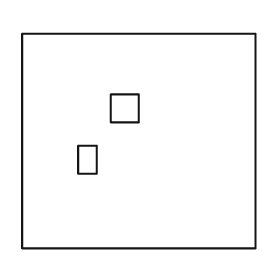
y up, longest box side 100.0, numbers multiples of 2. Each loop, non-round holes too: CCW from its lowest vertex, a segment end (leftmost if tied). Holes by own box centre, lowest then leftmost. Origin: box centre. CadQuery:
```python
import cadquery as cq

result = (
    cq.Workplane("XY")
    .moveTo(-50.0, -46.0)
    .lineTo(50.0, -46.0)
    .lineTo(50.0, 46.0)
    .lineTo(-50.0, 46.0)
    .close()
    .moveTo(-26.0, -14.0)
    .lineTo(-18.0, -14.0)
    .lineTo(-18.0, -2.0)
    .lineTo(-26.0, -2.0)
    .close()
    .moveTo(-12.0, 8.0)
    .lineTo(0.0, 8.0)
    .lineTo(0.0, 20.0)
    .lineTo(-12.0, 20.0)
    .close()
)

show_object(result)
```